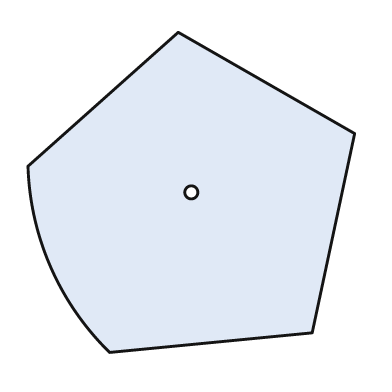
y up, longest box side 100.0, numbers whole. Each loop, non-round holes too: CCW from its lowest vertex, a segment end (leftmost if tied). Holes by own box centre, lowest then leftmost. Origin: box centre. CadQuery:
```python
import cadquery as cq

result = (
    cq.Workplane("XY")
    .moveTo(-25.0, -49.0)
    .lineTo(37.0, -43.0)
    .lineTo(50.0, 18.0)
    .lineTo(-4.0, 49.0)
    .lineTo(-50.0, 8.0)
    .threePointArc((-43.0, -23.0), (-25.0, -49.0))
    .close()
    .moveTo(0.0, 0.0)
    .circle(2.0)
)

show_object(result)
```